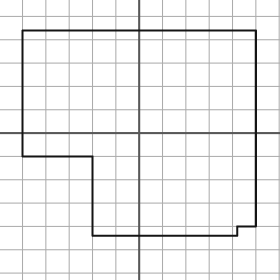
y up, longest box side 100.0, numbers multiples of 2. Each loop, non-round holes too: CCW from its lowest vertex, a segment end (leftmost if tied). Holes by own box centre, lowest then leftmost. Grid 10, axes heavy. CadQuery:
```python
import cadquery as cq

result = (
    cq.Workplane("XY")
    .moveTo(-20.0, -44.0)
    .lineTo(42.0, -44.0)
    .lineTo(42.0, -40.0)
    .lineTo(50.0, -40.0)
    .lineTo(50.0, 44.0)
    .lineTo(-50.0, 44.0)
    .lineTo(-50.0, -10.0)
    .lineTo(-20.0, -10.0)
    .close()
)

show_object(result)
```